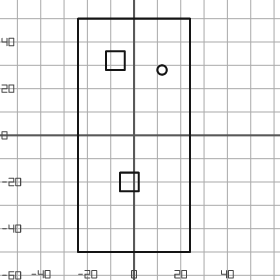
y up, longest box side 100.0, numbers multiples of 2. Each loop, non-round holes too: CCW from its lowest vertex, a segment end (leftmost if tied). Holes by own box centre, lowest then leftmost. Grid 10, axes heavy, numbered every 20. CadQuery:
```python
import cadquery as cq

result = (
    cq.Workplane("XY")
    .moveTo(-24.0, -50.0)
    .lineTo(24.0, -50.0)
    .lineTo(24.0, 50.0)
    .lineTo(-24.0, 50.0)
    .close()
    .moveTo(-6.0, -24.0)
    .lineTo(2.0, -24.0)
    .lineTo(2.0, -16.0)
    .lineTo(-6.0, -16.0)
    .close()
    .moveTo(12.0, 28.0)
    .circle(2.0)
    .moveTo(-12.0, 28.0)
    .lineTo(-4.0, 28.0)
    .lineTo(-4.0, 36.0)
    .lineTo(-12.0, 36.0)
    .close()
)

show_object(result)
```